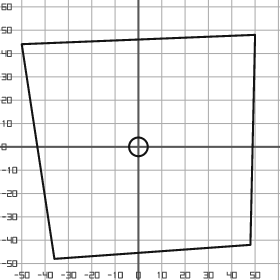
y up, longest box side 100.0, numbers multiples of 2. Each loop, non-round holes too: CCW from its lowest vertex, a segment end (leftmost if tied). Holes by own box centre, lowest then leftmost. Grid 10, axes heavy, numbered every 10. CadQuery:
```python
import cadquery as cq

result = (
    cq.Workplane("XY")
    .moveTo(-36.0, -48.0)
    .lineTo(48.0, -42.0)
    .lineTo(50.0, 48.0)
    .lineTo(-50.0, 44.0)
    .close()
    .moveTo(0.0, 0.0)
    .circle(4.0)
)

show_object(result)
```